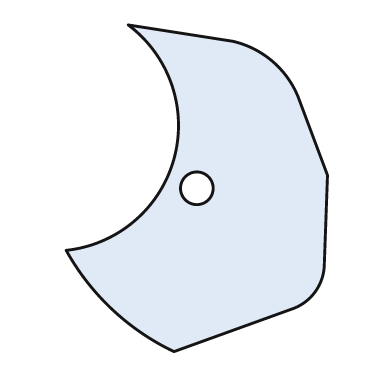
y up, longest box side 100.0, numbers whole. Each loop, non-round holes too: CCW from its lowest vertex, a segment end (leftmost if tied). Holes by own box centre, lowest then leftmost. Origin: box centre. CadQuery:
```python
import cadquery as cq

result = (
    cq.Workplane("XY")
    .moveTo(-7.0, -50.0)
    .lineTo(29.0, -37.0)
    .threePointArc((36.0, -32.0), (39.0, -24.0))
    .lineTo(40.0, 4.0)
    .lineTo(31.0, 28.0)
    .threePointArc((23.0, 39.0), (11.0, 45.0))
    .lineTo(-21.0, 50.0)
    .threePointArc((-7.0, 9.0), (-40.0, -19.0))
    .threePointArc((-26.0, -37.0), (-7.0, -50.0))
    .close()
    .moveTo(0.0, 0.0)
    .circle(5.0)
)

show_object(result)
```